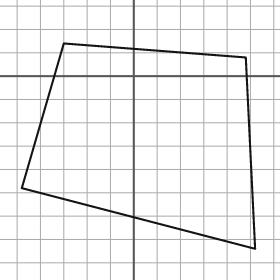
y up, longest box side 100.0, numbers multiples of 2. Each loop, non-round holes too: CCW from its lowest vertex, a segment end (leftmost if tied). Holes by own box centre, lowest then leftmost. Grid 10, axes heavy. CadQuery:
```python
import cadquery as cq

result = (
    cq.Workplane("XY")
    .moveTo(52.0, -74.0)
    .lineTo(48.0, 8.0)
    .lineTo(-30.0, 14.0)
    .lineTo(-48.0, -48.0)
    .close()
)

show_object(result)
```